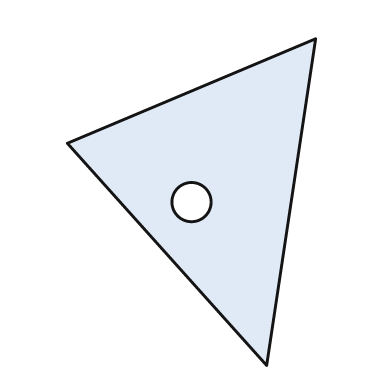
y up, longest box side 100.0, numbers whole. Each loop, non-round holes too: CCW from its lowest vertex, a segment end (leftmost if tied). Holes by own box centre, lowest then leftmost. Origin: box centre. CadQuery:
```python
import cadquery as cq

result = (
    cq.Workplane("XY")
    .moveTo(23.0, -50.0)
    .lineTo(38.0, 50.0)
    .lineTo(-38.0, 18.0)
    .close()
    .moveTo(0.0, 0.0)
    .circle(6.0)
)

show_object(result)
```